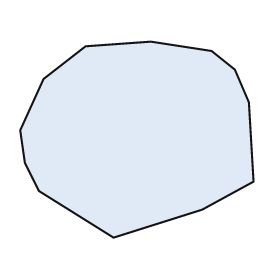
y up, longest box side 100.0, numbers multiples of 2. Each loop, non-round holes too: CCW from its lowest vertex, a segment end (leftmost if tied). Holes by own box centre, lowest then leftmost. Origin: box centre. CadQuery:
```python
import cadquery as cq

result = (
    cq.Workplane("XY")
    .moveTo(-10.0, -42.0)
    .lineTo(28.0, -30.0)
    .lineTo(50.0, -18.0)
    .lineTo(48.0, 16.0)
    .lineTo(42.0, 30.0)
    .lineTo(32.0, 38.0)
    .lineTo(6.0, 42.0)
    .lineTo(-22.0, 40.0)
    .lineTo(-40.0, 26.0)
    .lineTo(-50.0, 4.0)
    .lineTo(-48.0, -10.0)
    .lineTo(-42.0, -22.0)
    .close()
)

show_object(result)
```